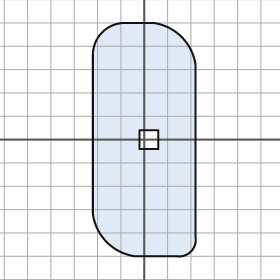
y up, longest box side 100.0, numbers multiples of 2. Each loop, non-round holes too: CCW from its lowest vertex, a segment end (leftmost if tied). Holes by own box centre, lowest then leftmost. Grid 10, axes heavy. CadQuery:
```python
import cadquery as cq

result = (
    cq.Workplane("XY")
    .moveTo(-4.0, -50.0)
    .lineTo(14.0, -50.0)
    .threePointArc((20.0, -48.0), (22.0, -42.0))
    .lineTo(22.0, 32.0)
    .threePointArc((16.0, 44.0), (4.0, 50.0))
    .lineTo(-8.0, 50.0)
    .threePointArc((-18.0, 46.0), (-22.0, 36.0))
    .lineTo(-22.0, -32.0)
    .threePointArc((-16.0, -44.0), (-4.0, -50.0))
    .close()
    .moveTo(-2.0, -4.0)
    .lineTo(6.0, -4.0)
    .lineTo(6.0, 4.0)
    .lineTo(-2.0, 4.0)
    .close()
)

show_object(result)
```